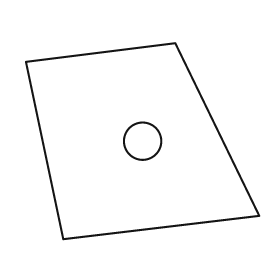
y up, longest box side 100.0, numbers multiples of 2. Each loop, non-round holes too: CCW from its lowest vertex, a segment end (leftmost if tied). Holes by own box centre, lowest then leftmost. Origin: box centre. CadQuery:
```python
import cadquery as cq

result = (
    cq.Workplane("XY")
    .moveTo(-34.0, -42.0)
    .lineTo(50.0, -32.0)
    .lineTo(14.0, 42.0)
    .lineTo(-50.0, 34.0)
    .close()
    .moveTo(0.0, 0.0)
    .circle(8.0)
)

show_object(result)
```